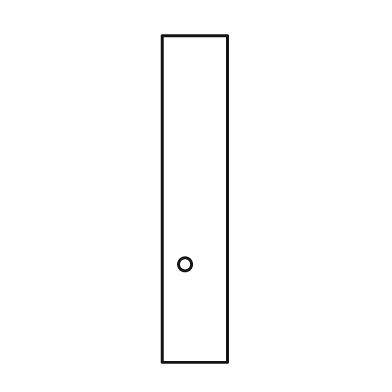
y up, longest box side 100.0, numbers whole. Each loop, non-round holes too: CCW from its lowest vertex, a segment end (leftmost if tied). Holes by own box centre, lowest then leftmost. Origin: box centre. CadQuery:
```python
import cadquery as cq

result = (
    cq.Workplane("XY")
    .moveTo(-10.0, -50.0)
    .lineTo(10.0, -50.0)
    .lineTo(10.0, 50.0)
    .lineTo(-10.0, 50.0)
    .close()
    .moveTo(-3.0, -20.0)
    .circle(2.0)
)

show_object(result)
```